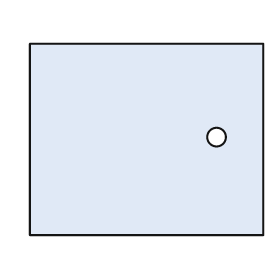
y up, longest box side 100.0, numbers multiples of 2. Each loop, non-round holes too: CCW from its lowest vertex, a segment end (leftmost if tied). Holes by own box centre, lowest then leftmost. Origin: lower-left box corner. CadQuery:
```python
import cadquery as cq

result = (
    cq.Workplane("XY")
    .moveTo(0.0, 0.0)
    .lineTo(100.0, 0.0)
    .lineTo(100.0, 82.0)
    .lineTo(0.0, 82.0)
    .close()
    .moveTo(80.0, 42.0)
    .circle(4.0)
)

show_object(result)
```